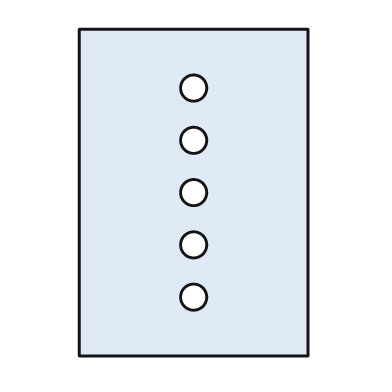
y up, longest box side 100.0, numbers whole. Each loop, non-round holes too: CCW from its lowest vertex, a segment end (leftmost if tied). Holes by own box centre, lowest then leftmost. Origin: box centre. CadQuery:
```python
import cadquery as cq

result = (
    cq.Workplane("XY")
    .moveTo(-35.0, -50.0)
    .lineTo(35.0, -50.0)
    .lineTo(35.0, 50.0)
    .lineTo(-35.0, 50.0)
    .close()
    .moveTo(0.0, -32.0)
    .circle(4.0)
    .moveTo(0.0, -16.0)
    .circle(4.0)
    .moveTo(0.0, 0.0)
    .circle(4.0)
    .moveTo(0.0, 16.0)
    .circle(4.0)
    .moveTo(0.0, 32.0)
    .circle(4.0)
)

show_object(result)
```